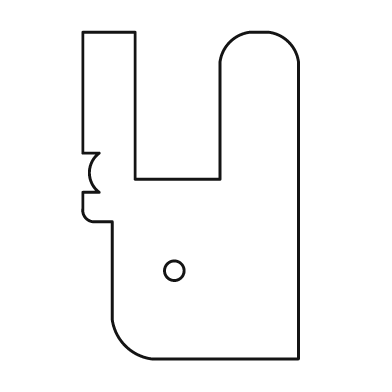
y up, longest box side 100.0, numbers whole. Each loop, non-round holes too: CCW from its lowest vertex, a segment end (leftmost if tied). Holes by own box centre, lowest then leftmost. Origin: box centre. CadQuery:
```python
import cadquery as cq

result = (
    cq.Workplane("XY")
    .moveTo(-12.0, -50.0)
    .lineTo(33.0, -50.0)
    .lineTo(33.0, 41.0)
    .threePointArc((30.0, 47.0), (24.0, 50.0))
    .lineTo(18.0, 50.0)
    .threePointArc((12.0, 47.0), (9.0, 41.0))
    .lineTo(9.0, 5.0)
    .lineTo(-17.0, 5.0)
    .lineTo(-17.0, 50.0)
    .lineTo(-33.0, 50.0)
    .lineTo(-33.0, 13.0)
    .lineTo(-28.0, 13.0)
    .threePointArc((-31.0, 7.0), (-28.0, 1.0))
    .lineTo(-33.0, 1.0)
    .lineTo(-33.0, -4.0)
    .threePointArc((-32.0, -7.0), (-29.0, -8.0))
    .lineTo(-24.0, -8.0)
    .lineTo(-24.0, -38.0)
    .threePointArc((-20.0, -46.0), (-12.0, -50.0))
    .close()
    .moveTo(-5.0, -23.0)
    .circle(3.0)
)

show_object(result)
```